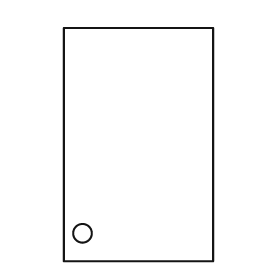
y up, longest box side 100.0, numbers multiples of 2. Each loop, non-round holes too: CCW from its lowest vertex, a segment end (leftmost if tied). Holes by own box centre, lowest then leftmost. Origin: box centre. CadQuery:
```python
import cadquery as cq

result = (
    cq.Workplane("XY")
    .moveTo(-32.0, -50.0)
    .lineTo(32.0, -50.0)
    .lineTo(32.0, 50.0)
    .lineTo(-32.0, 50.0)
    .close()
    .moveTo(-24.0, -38.0)
    .circle(4.0)
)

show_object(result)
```